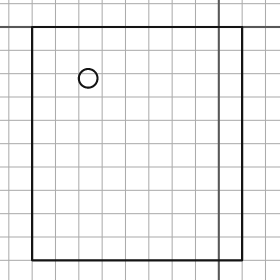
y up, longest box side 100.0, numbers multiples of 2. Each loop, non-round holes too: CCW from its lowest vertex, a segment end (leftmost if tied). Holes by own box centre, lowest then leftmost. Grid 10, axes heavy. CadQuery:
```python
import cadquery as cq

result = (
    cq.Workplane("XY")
    .moveTo(-80.0, -100.0)
    .lineTo(10.0, -100.0)
    .lineTo(10.0, 0.0)
    .lineTo(-80.0, 0.0)
    .close()
    .moveTo(-56.0, -22.0)
    .circle(4.0)
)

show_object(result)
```